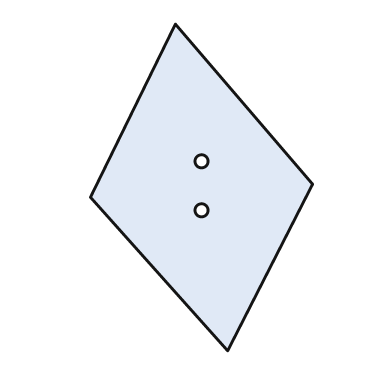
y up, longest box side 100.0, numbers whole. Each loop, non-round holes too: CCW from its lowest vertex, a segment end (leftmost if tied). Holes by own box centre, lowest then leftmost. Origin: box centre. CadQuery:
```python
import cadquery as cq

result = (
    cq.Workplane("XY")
    .moveTo(8.0, -50.0)
    .lineTo(34.0, 1.0)
    .lineTo(-8.0, 50.0)
    .lineTo(-34.0, -3.0)
    .close()
    .moveTo(0.0, -7.0)
    .circle(2.0)
    .moveTo(0.0, 8.0)
    .circle(2.0)
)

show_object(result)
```